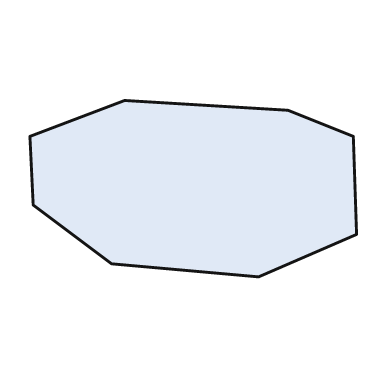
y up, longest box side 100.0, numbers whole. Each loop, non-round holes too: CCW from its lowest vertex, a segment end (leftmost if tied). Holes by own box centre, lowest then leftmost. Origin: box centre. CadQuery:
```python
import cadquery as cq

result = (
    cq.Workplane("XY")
    .moveTo(20.0, -27.0)
    .lineTo(50.0, -14.0)
    .lineTo(49.0, 16.0)
    .lineTo(29.0, 24.0)
    .lineTo(-21.0, 27.0)
    .lineTo(-50.0, 16.0)
    .lineTo(-49.0, -5.0)
    .lineTo(-25.0, -23.0)
    .close()
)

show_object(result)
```